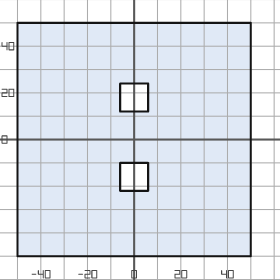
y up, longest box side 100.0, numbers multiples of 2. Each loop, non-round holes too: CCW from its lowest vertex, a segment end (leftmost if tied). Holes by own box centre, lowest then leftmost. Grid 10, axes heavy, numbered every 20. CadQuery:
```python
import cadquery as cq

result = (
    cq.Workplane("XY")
    .moveTo(-50.0, -50.0)
    .lineTo(50.0, -50.0)
    .lineTo(50.0, 50.0)
    .lineTo(-50.0, 50.0)
    .close()
    .moveTo(-6.0, -22.0)
    .lineTo(6.0, -22.0)
    .lineTo(6.0, -10.0)
    .lineTo(-6.0, -10.0)
    .close()
    .moveTo(-6.0, 12.0)
    .lineTo(6.0, 12.0)
    .lineTo(6.0, 24.0)
    .lineTo(-6.0, 24.0)
    .close()
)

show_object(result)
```